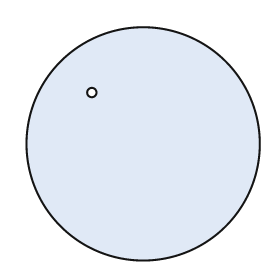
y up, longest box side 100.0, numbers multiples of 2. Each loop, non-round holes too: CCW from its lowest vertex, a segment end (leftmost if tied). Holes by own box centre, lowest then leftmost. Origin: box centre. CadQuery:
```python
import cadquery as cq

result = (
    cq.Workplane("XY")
    .moveTo(0.0, 0.0)
    .circle(50.0)
    .moveTo(-22.0, 22.0)
    .circle(2.0)
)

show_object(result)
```